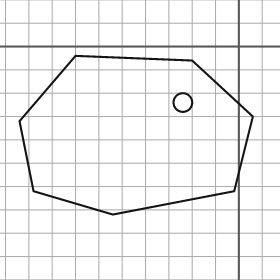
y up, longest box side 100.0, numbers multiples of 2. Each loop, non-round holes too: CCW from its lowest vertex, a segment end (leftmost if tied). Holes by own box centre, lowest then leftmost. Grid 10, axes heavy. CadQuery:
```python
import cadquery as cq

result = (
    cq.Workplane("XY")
    .moveTo(-54.0, -72.0)
    .lineTo(-2.0, -62.0)
    .lineTo(6.0, -30.0)
    .lineTo(-20.0, -6.0)
    .lineTo(-70.0, -4.0)
    .lineTo(-94.0, -32.0)
    .lineTo(-88.0, -62.0)
    .close()
    .moveTo(-24.0, -24.0)
    .circle(4.0)
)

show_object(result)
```